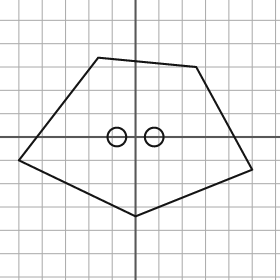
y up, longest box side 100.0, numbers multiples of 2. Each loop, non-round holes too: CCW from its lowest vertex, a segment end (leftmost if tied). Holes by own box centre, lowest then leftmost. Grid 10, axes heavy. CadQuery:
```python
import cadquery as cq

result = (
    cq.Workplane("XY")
    .moveTo(0.0, -34.0)
    .lineTo(50.0, -14.0)
    .lineTo(26.0, 30.0)
    .lineTo(-16.0, 34.0)
    .lineTo(-50.0, -10.0)
    .close()
    .moveTo(-8.0, 0.0)
    .circle(4.0)
    .moveTo(8.0, 0.0)
    .circle(4.0)
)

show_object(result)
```